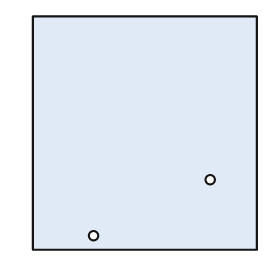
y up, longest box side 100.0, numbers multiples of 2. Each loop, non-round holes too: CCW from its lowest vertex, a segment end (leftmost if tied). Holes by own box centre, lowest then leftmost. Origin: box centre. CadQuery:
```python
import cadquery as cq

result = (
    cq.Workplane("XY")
    .moveTo(-48.0, -50.0)
    .lineTo(48.0, -50.0)
    .lineTo(48.0, 50.0)
    .lineTo(-48.0, 50.0)
    .close()
    .moveTo(-22.0, -44.0)
    .circle(2.0)
    .moveTo(28.0, -20.0)
    .circle(2.0)
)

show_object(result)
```